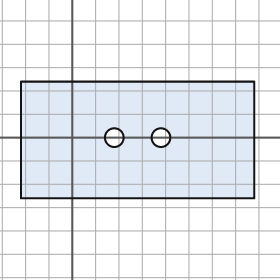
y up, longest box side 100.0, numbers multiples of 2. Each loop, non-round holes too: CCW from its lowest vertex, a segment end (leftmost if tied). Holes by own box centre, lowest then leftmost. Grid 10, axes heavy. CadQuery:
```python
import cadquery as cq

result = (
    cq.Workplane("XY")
    .moveTo(-22.0, -26.0)
    .lineTo(78.0, -26.0)
    .lineTo(78.0, 24.0)
    .lineTo(-22.0, 24.0)
    .close()
    .moveTo(18.0, 0.0)
    .circle(4.0)
    .moveTo(38.0, 0.0)
    .circle(4.0)
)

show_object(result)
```